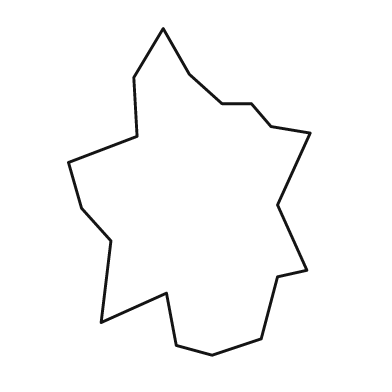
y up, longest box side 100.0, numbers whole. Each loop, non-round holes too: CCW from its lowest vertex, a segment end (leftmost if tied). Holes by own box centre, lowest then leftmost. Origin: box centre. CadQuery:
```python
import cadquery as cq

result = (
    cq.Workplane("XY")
    .moveTo(7.0, -50.0)
    .lineTo(22.0, -45.0)
    .lineTo(27.0, -26.0)
    .lineTo(36.0, -24.0)
    .lineTo(27.0, -4.0)
    .lineTo(37.0, 18.0)
    .lineTo(25.0, 20.0)
    .lineTo(19.0, 27.0)
    .lineTo(10.0, 27.0)
    .lineTo(0.0, 36.0)
    .lineTo(-8.0, 50.0)
    .lineTo(-17.0, 35.0)
    .lineTo(-16.0, 17.0)
    .lineTo(-37.0, 9.0)
    .lineTo(-33.0, -5.0)
    .lineTo(-24.0, -15.0)
    .lineTo(-27.0, -40.0)
    .lineTo(-7.0, -31.0)
    .lineTo(-4.0, -47.0)
    .close()
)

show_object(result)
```